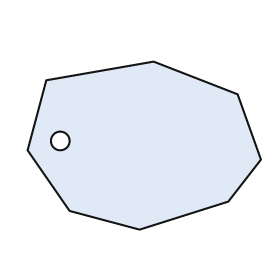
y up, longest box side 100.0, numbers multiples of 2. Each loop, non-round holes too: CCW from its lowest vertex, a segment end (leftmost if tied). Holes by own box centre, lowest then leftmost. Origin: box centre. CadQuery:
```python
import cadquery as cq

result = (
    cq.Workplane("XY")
    .moveTo(-2.0, -36.0)
    .lineTo(36.0, -24.0)
    .lineTo(50.0, -6.0)
    .lineTo(40.0, 22.0)
    .lineTo(4.0, 36.0)
    .lineTo(-42.0, 28.0)
    .lineTo(-50.0, -2.0)
    .lineTo(-32.0, -28.0)
    .close()
    .moveTo(-36.0, 2.0)
    .circle(4.0)
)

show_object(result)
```